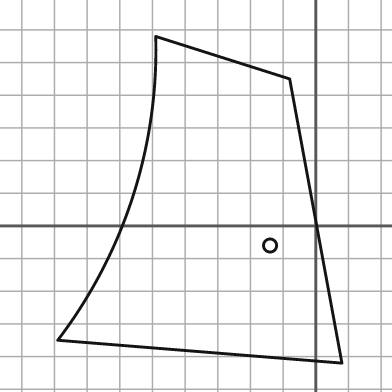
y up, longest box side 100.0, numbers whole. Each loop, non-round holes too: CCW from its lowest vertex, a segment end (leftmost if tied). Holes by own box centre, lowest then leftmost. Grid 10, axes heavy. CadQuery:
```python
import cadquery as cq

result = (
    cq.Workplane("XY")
    .moveTo(8.0, -42.0)
    .lineTo(-8.0, 45.0)
    .lineTo(-49.0, 58.0)
    .threePointArc((-56.0, 9.0), (-79.0, -35.0))
    .close()
    .moveTo(-14.0, -6.0)
    .circle(2.0)
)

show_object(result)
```